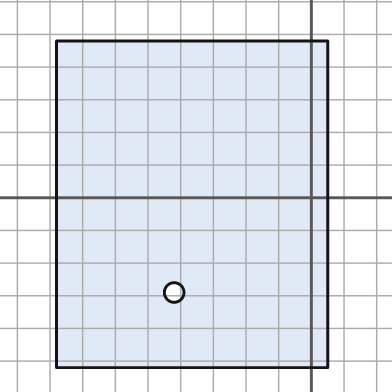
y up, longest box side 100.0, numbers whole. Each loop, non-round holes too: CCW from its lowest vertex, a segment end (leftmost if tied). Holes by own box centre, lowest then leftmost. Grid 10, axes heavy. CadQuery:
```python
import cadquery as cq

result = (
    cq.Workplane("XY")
    .moveTo(-78.0, -52.0)
    .lineTo(5.0, -52.0)
    .lineTo(5.0, 48.0)
    .lineTo(-78.0, 48.0)
    .close()
    .moveTo(-42.0, -29.0)
    .circle(3.0)
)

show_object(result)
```